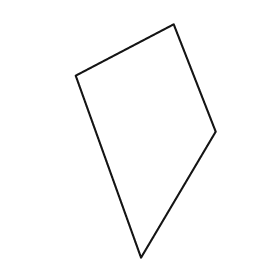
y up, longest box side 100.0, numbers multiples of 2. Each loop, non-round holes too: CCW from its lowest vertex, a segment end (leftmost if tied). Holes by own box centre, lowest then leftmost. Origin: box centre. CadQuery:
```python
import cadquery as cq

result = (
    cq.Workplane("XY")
    .moveTo(-2.0, -50.0)
    .lineTo(30.0, 4.0)
    .lineTo(12.0, 50.0)
    .lineTo(-30.0, 28.0)
    .close()
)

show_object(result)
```